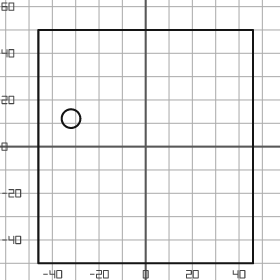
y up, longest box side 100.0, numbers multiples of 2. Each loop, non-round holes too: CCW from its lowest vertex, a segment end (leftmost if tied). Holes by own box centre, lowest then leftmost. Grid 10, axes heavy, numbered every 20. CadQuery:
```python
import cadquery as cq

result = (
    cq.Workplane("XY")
    .moveTo(-46.0, -50.0)
    .lineTo(46.0, -50.0)
    .lineTo(46.0, 50.0)
    .lineTo(-46.0, 50.0)
    .close()
    .moveTo(-32.0, 12.0)
    .circle(4.0)
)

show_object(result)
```